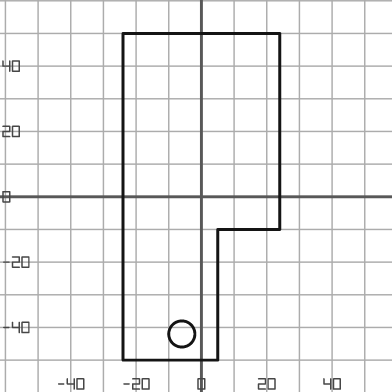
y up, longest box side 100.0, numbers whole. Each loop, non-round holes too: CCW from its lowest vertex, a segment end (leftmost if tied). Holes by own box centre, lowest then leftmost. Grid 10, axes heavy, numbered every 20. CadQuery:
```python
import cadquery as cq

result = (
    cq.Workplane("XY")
    .moveTo(-24.0, -50.0)
    .lineTo(5.0, -50.0)
    .lineTo(5.0, -10.0)
    .lineTo(24.0, -10.0)
    .lineTo(24.0, 50.0)
    .lineTo(-24.0, 50.0)
    .close()
    .moveTo(-6.0, -42.0)
    .circle(4.0)
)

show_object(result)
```